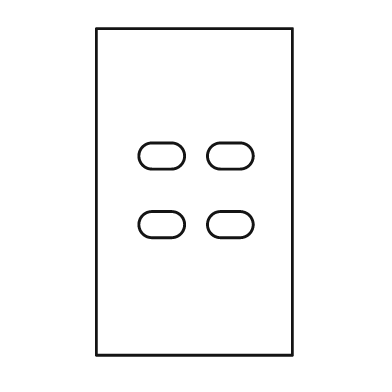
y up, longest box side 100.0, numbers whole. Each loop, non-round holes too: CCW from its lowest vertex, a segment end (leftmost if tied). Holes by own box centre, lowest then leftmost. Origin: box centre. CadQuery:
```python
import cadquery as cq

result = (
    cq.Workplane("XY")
    .moveTo(-30.0, -50.0)
    .lineTo(30.0, -50.0)
    .lineTo(30.0, 50.0)
    .lineTo(-30.0, 50.0)
    .close()
    .moveTo(-13.0, -14.0)
    .lineTo(-7.0, -14.0)
    .threePointArc((-3.0, -10.0), (-7.0, -6.0))
    .lineTo(-13.0, -6.0)
    .threePointArc((-17.0, -10.0), (-13.0, -14.0))
    .close()
    .moveTo(8.0, -14.0)
    .lineTo(14.0, -14.0)
    .threePointArc((18.0, -10.0), (14.0, -6.0))
    .lineTo(8.0, -6.0)
    .threePointArc((4.0, -10.0), (8.0, -14.0))
    .close()
    .moveTo(-13.0, 7.0)
    .lineTo(-7.0, 7.0)
    .threePointArc((-3.0, 11.0), (-7.0, 15.0))
    .lineTo(-13.0, 15.0)
    .threePointArc((-17.0, 11.0), (-13.0, 7.0))
    .close()
    .moveTo(8.0, 7.0)
    .lineTo(14.0, 7.0)
    .threePointArc((18.0, 11.0), (14.0, 15.0))
    .lineTo(8.0, 15.0)
    .threePointArc((4.0, 11.0), (8.0, 7.0))
    .close()
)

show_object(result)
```